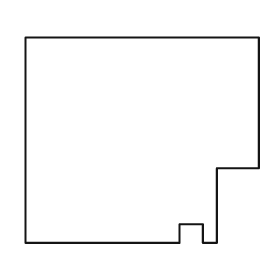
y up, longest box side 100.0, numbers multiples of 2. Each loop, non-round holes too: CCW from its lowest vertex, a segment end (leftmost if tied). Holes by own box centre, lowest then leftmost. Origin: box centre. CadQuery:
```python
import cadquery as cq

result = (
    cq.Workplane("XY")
    .moveTo(-50.0, -44.0)
    .lineTo(16.0, -44.0)
    .lineTo(16.0, -36.0)
    .lineTo(26.0, -36.0)
    .lineTo(26.0, -44.0)
    .lineTo(32.0, -44.0)
    .lineTo(32.0, -12.0)
    .lineTo(50.0, -12.0)
    .lineTo(50.0, 44.0)
    .lineTo(-50.0, 44.0)
    .close()
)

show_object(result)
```